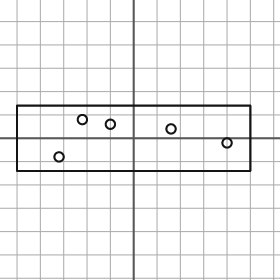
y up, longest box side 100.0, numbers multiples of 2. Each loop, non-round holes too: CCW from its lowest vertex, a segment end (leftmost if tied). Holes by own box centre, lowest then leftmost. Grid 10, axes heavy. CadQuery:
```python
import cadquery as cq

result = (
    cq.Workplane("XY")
    .moveTo(-50.0, -14.0)
    .lineTo(50.0, -14.0)
    .lineTo(50.0, 14.0)
    .lineTo(-50.0, 14.0)
    .close()
    .moveTo(-32.0, -8.0)
    .circle(2.0)
    .moveTo(40.0, -2.0)
    .circle(2.0)
    .moveTo(16.0, 4.0)
    .circle(2.0)
    .moveTo(-10.0, 6.0)
    .circle(2.0)
    .moveTo(-22.0, 8.0)
    .circle(2.0)
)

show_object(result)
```